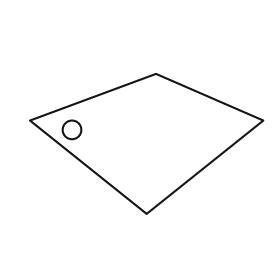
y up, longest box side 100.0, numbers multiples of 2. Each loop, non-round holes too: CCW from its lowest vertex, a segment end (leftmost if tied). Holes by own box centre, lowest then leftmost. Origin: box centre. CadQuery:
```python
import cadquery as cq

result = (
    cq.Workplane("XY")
    .moveTo(0.0, -30.0)
    .lineTo(50.0, 10.0)
    .lineTo(4.0, 30.0)
    .lineTo(-50.0, 10.0)
    .close()
    .moveTo(-32.0, 6.0)
    .circle(4.0)
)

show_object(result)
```